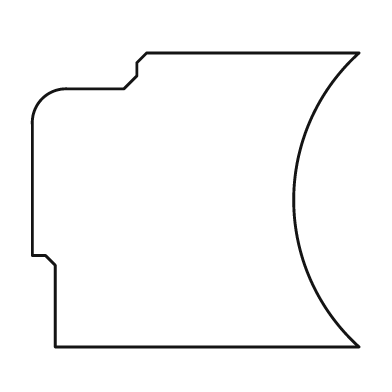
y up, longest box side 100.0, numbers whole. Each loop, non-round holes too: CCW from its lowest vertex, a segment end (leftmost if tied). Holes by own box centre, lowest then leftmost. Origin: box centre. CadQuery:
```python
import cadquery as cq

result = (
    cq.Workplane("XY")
    .moveTo(-43.0, -45.0)
    .lineTo(50.0, -45.0)
    .threePointArc((30.0, 0.0), (50.0, 45.0))
    .lineTo(-15.0, 45.0)
    .lineTo(-18.0, 42.0)
    .lineTo(-18.0, 38.0)
    .lineTo(-22.0, 34.0)
    .lineTo(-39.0, 34.0)
    .threePointArc((-47.0, 31.0), (-50.0, 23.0))
    .lineTo(-50.0, -17.0)
    .lineTo(-46.0, -17.0)
    .lineTo(-43.0, -20.0)
    .close()
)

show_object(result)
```